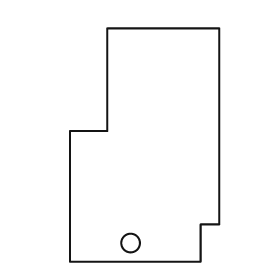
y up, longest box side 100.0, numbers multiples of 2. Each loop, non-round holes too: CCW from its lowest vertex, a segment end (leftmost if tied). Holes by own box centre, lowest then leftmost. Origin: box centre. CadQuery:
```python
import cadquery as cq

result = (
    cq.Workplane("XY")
    .moveTo(-32.0, -50.0)
    .lineTo(24.0, -50.0)
    .lineTo(24.0, -34.0)
    .lineTo(32.0, -34.0)
    .lineTo(32.0, 50.0)
    .lineTo(-16.0, 50.0)
    .lineTo(-16.0, 6.0)
    .lineTo(-32.0, 6.0)
    .close()
    .moveTo(-6.0, -42.0)
    .circle(4.0)
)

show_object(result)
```